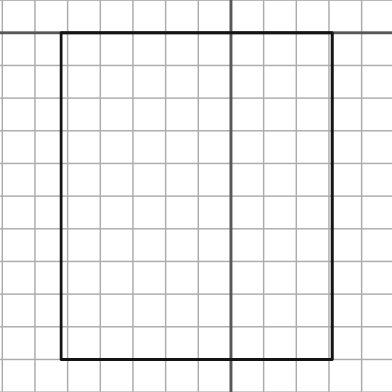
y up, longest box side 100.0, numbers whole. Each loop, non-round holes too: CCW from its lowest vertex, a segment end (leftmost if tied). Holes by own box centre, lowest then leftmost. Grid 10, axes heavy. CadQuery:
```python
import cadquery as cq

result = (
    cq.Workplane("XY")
    .moveTo(-52.0, -100.0)
    .lineTo(31.0, -100.0)
    .lineTo(31.0, 0.0)
    .lineTo(-52.0, 0.0)
    .close()
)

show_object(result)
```